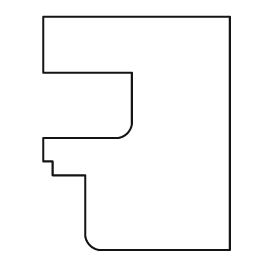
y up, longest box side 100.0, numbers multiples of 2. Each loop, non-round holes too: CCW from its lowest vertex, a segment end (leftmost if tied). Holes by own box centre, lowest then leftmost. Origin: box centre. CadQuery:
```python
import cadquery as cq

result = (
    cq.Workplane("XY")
    .moveTo(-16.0, -50.0)
    .lineTo(40.0, -50.0)
    .lineTo(40.0, 50.0)
    .lineTo(-40.0, 50.0)
    .lineTo(-40.0, 26.0)
    .lineTo(-2.0, 26.0)
    .lineTo(-2.0, 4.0)
    .threePointArc((-4.0, 0.0), (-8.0, -2.0))
    .lineTo(-40.0, -2.0)
    .lineTo(-40.0, -12.0)
    .lineTo(-36.0, -12.0)
    .lineTo(-36.0, -18.0)
    .lineTo(-22.0, -18.0)
    .lineTo(-22.0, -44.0)
    .threePointArc((-20.0, -48.0), (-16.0, -50.0))
    .close()
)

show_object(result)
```